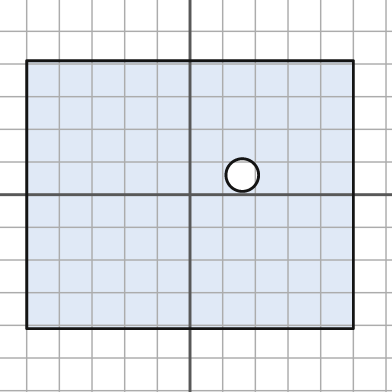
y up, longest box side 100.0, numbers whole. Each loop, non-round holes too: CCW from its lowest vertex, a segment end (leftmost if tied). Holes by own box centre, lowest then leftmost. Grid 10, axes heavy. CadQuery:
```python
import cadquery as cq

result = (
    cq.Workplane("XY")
    .moveTo(-50.0, -41.0)
    .lineTo(50.0, -41.0)
    .lineTo(50.0, 41.0)
    .lineTo(-50.0, 41.0)
    .close()
    .moveTo(16.0, 6.0)
    .circle(5.0)
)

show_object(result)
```